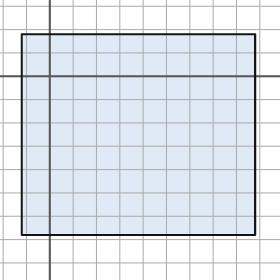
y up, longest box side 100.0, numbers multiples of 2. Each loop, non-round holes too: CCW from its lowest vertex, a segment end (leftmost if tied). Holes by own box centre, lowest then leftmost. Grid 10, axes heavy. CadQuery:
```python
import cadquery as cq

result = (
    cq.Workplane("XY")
    .moveTo(-12.0, -68.0)
    .lineTo(88.0, -68.0)
    .lineTo(88.0, 18.0)
    .lineTo(-12.0, 18.0)
    .close()
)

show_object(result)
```